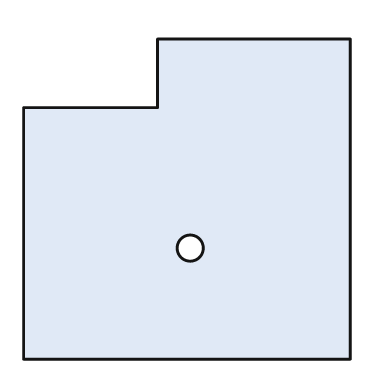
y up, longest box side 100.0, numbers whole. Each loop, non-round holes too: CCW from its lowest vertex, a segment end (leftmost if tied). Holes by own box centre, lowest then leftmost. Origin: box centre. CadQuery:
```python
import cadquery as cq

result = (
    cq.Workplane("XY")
    .moveTo(-50.0, -49.0)
    .lineTo(50.0, -49.0)
    .lineTo(50.0, 49.0)
    .lineTo(-9.0, 49.0)
    .lineTo(-9.0, 28.0)
    .lineTo(-50.0, 28.0)
    .close()
    .moveTo(1.0, -15.0)
    .circle(4.0)
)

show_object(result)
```